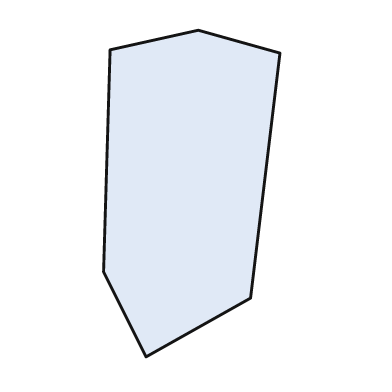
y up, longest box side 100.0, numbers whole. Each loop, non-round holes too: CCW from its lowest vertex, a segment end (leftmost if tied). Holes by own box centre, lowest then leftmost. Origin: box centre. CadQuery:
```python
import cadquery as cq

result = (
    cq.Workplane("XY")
    .moveTo(-14.0, -50.0)
    .lineTo(18.0, -32.0)
    .lineTo(27.0, 43.0)
    .lineTo(2.0, 50.0)
    .lineTo(-25.0, 44.0)
    .lineTo(-27.0, -24.0)
    .close()
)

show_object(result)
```